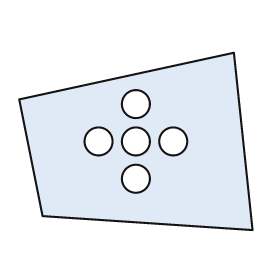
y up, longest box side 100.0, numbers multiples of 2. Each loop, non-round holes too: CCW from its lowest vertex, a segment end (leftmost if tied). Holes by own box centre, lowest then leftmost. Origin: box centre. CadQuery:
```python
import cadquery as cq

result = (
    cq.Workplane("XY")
    .moveTo(50.0, -38.0)
    .lineTo(42.0, 38.0)
    .lineTo(-50.0, 18.0)
    .lineTo(-40.0, -32.0)
    .close()
    .moveTo(0.0, -16.0)
    .circle(6.0)
    .moveTo(-16.0, 0.0)
    .circle(6.0)
    .moveTo(0.0, 0.0)
    .circle(6.0)
    .moveTo(16.0, 0.0)
    .circle(6.0)
    .moveTo(0.0, 16.0)
    .circle(6.0)
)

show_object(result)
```